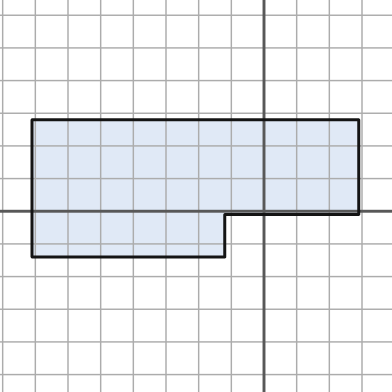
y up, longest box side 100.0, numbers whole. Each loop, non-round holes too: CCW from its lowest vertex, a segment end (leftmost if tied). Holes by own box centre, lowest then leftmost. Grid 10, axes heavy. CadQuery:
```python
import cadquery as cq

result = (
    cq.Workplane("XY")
    .moveTo(-71.0, -14.0)
    .lineTo(-12.0, -14.0)
    .lineTo(-12.0, -1.0)
    .lineTo(29.0, -1.0)
    .lineTo(29.0, 28.0)
    .lineTo(-71.0, 28.0)
    .close()
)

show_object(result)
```